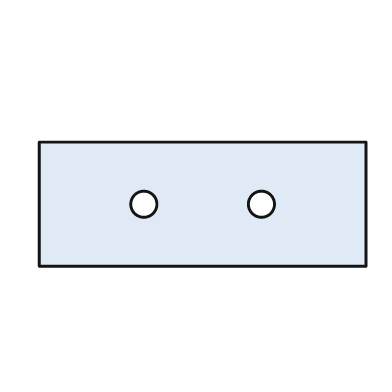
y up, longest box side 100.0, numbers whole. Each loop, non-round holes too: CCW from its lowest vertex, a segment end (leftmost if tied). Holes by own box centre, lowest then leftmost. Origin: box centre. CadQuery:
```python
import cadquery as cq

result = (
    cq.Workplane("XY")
    .moveTo(-50.0, -19.0)
    .lineTo(50.0, -19.0)
    .lineTo(50.0, 19.0)
    .lineTo(-50.0, 19.0)
    .close()
    .moveTo(-18.0, 0.0)
    .circle(4.0)
    .moveTo(18.0, 0.0)
    .circle(4.0)
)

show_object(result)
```